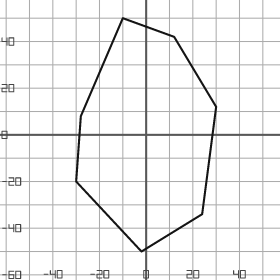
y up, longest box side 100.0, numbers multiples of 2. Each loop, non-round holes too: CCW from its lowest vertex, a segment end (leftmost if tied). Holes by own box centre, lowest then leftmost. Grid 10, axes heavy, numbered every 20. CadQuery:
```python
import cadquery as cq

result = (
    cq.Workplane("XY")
    .moveTo(-2.0, -50.0)
    .lineTo(24.0, -34.0)
    .lineTo(30.0, 12.0)
    .lineTo(12.0, 42.0)
    .lineTo(-10.0, 50.0)
    .lineTo(-28.0, 8.0)
    .lineTo(-30.0, -20.0)
    .close()
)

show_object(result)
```